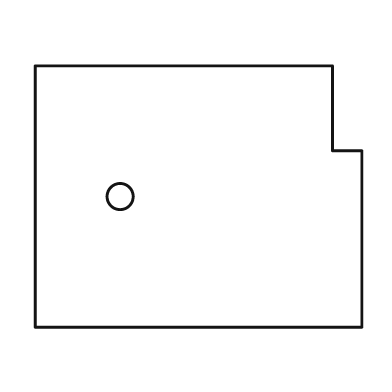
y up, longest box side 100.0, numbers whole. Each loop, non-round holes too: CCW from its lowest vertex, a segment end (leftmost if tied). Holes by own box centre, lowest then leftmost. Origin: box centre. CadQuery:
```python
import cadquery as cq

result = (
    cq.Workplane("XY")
    .moveTo(-50.0, -40.0)
    .lineTo(50.0, -40.0)
    .lineTo(50.0, 14.0)
    .lineTo(41.0, 14.0)
    .lineTo(41.0, 40.0)
    .lineTo(-50.0, 40.0)
    .close()
    .moveTo(-24.0, 0.0)
    .circle(4.0)
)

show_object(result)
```